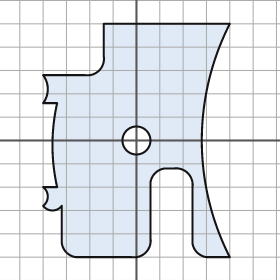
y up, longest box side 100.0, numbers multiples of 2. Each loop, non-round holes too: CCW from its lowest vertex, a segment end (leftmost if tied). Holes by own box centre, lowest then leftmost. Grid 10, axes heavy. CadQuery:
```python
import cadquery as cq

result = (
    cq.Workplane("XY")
    .moveTo(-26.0, -50.0)
    .lineTo(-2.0, -50.0)
    .threePointArc((4.0, -48.0), (6.0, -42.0))
    .lineTo(6.0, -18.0)
    .threePointArc((8.0, -14.0), (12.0, -12.0))
    .lineTo(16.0, -12.0)
    .threePointArc((22.0, -14.0), (24.0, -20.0))
    .lineTo(24.0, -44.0)
    .threePointArc((26.0, -48.0), (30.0, -50.0))
    .lineTo(40.0, -50.0)
    .threePointArc((28.0, 0.0), (40.0, 50.0))
    .lineTo(-14.0, 50.0)
    .lineTo(-14.0, 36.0)
    .threePointArc((-16.0, 30.0), (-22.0, 28.0))
    .lineTo(-40.0, 28.0)
    .threePointArc((-38.0, 22.0), (-40.0, 16.0))
    .lineTo(-34.0, 16.0)
    .threePointArc((-36.0, -2.0), (-34.0, -20.0))
    .lineTo(-40.0, -20.0)
    .threePointArc((-38.0, -24.0), (-40.0, -28.0))
    .threePointArc((-36.0, -30.0), (-32.0, -28.0))
    .lineTo(-32.0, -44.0)
    .threePointArc((-30.0, -48.0), (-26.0, -50.0))
    .close()
    .moveTo(0.0, 0.0)
    .circle(6.0)
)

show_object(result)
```